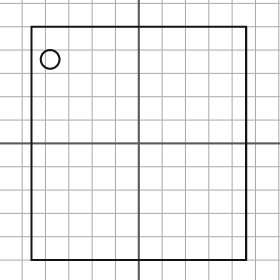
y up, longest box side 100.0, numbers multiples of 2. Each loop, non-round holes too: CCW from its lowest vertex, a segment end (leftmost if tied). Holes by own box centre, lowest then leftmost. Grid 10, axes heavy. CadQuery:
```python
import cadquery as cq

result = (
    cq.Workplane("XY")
    .moveTo(-46.0, -50.0)
    .lineTo(46.0, -50.0)
    .lineTo(46.0, 50.0)
    .lineTo(-46.0, 50.0)
    .close()
    .moveTo(-38.0, 36.0)
    .circle(4.0)
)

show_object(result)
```